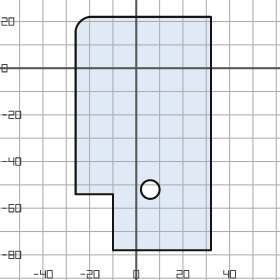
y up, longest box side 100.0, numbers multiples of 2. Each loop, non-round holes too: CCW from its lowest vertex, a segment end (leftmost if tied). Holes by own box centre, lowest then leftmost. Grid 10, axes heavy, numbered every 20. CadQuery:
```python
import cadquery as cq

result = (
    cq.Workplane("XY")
    .moveTo(-10.0, -78.0)
    .lineTo(32.0, -78.0)
    .lineTo(32.0, 22.0)
    .lineTo(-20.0, 22.0)
    .threePointArc((-24.0, 20.0), (-26.0, 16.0))
    .lineTo(-26.0, -54.0)
    .lineTo(-10.0, -54.0)
    .close()
    .moveTo(6.0, -52.0)
    .circle(4.0)
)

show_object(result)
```